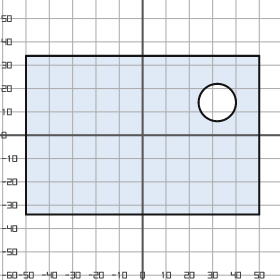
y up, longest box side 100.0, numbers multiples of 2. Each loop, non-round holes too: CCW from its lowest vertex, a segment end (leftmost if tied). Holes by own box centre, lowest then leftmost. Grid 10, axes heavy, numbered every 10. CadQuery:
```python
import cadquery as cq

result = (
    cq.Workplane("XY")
    .moveTo(-50.0, -34.0)
    .lineTo(50.0, -34.0)
    .lineTo(50.0, 34.0)
    .lineTo(-50.0, 34.0)
    .close()
    .moveTo(32.0, 14.0)
    .circle(8.0)
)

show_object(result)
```